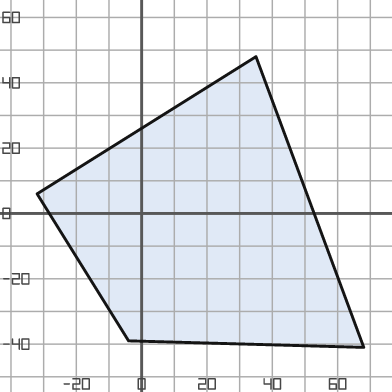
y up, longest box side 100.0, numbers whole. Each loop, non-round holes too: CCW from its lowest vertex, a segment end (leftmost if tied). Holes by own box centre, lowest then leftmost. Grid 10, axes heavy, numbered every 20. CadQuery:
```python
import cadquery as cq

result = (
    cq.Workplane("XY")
    .moveTo(68.0, -41.0)
    .lineTo(35.0, 48.0)
    .lineTo(-32.0, 6.0)
    .lineTo(-4.0, -39.0)
    .close()
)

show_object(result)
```